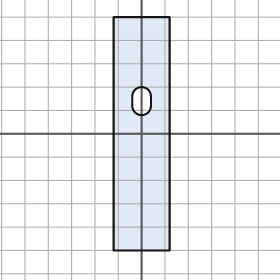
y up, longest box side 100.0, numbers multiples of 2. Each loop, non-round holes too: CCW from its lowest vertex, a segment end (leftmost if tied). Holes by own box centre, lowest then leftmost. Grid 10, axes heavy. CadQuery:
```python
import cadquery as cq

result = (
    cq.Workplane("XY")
    .moveTo(-12.0, -50.0)
    .lineTo(12.0, -50.0)
    .lineTo(12.0, 50.0)
    .lineTo(-12.0, 50.0)
    .close()
    .moveTo(-4.0, 12.0)
    .threePointArc((0.0, 8.0), (4.0, 12.0))
    .lineTo(4.0, 16.0)
    .threePointArc((0.0, 20.0), (-4.0, 16.0))
    .close()
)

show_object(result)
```